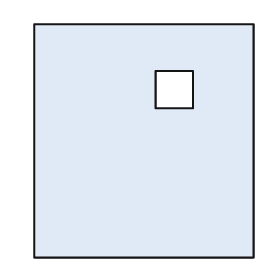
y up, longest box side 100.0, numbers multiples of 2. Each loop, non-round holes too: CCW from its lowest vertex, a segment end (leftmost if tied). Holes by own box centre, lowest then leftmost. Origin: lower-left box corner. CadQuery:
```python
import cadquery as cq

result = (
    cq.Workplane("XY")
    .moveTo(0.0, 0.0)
    .lineTo(94.0, 0.0)
    .lineTo(94.0, 100.0)
    .lineTo(0.0, 100.0)
    .close()
    .moveTo(52.0, 64.0)
    .lineTo(68.0, 64.0)
    .lineTo(68.0, 80.0)
    .lineTo(52.0, 80.0)
    .close()
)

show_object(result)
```